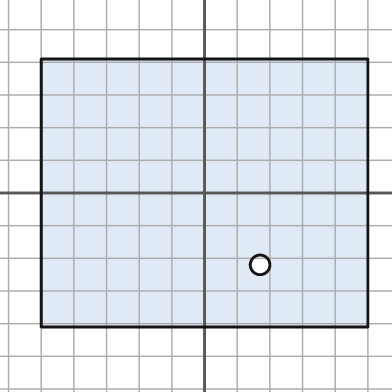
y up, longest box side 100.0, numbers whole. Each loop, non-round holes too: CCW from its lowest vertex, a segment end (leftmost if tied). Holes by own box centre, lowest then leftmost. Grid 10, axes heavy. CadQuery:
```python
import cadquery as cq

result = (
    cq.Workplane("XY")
    .moveTo(-50.0, -41.0)
    .lineTo(50.0, -41.0)
    .lineTo(50.0, 41.0)
    .lineTo(-50.0, 41.0)
    .close()
    .moveTo(17.0, -22.0)
    .circle(3.0)
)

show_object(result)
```